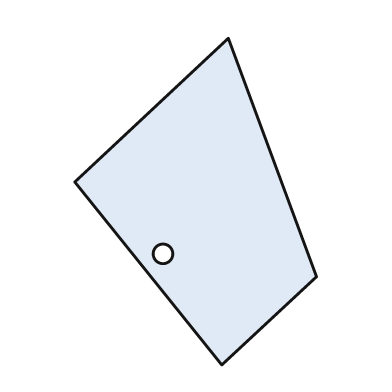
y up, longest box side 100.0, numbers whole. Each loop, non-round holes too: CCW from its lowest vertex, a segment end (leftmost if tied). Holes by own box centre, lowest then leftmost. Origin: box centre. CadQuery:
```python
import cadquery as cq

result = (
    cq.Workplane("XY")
    .moveTo(8.0, -50.0)
    .lineTo(37.0, -23.0)
    .lineTo(10.0, 50.0)
    .lineTo(-37.0, 6.0)
    .close()
    .moveTo(-10.0, -16.0)
    .circle(3.0)
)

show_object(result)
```